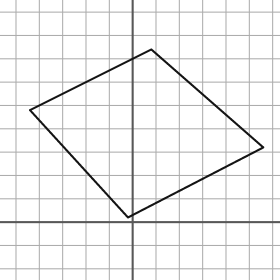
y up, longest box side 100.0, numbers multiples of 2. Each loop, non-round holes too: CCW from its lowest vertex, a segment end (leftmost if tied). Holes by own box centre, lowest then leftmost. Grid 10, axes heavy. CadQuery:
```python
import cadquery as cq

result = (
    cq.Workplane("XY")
    .moveTo(-2.0, 2.0)
    .lineTo(56.0, 32.0)
    .lineTo(8.0, 74.0)
    .lineTo(-44.0, 48.0)
    .close()
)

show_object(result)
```